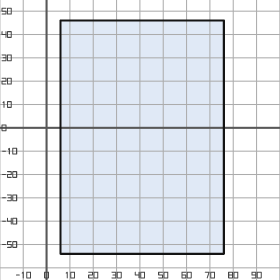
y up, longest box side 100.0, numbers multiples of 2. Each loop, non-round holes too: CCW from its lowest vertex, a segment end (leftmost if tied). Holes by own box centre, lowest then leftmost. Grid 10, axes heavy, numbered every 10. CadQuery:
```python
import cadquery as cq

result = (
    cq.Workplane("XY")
    .moveTo(6.0, -54.0)
    .lineTo(76.0, -54.0)
    .lineTo(76.0, 46.0)
    .lineTo(6.0, 46.0)
    .close()
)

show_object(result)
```